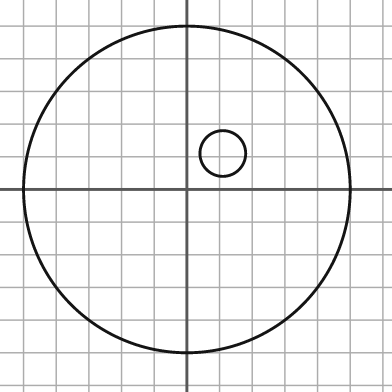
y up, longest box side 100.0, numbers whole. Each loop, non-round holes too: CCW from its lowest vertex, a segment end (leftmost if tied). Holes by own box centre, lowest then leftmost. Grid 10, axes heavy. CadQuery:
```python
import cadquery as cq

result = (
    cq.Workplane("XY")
    .moveTo(0.0, 0.0)
    .circle(50.0)
    .moveTo(11.0, 11.0)
    .circle(7.0)
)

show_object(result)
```